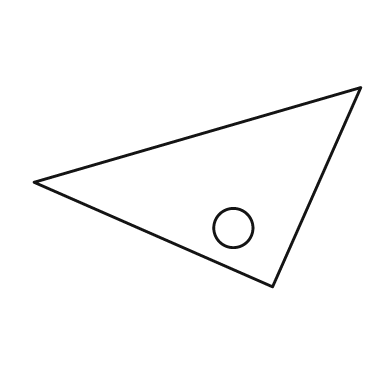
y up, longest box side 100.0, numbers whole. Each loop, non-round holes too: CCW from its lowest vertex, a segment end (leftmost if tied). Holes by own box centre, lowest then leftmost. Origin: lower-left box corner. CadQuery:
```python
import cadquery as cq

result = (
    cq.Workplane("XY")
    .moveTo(73.0, 0.0)
    .lineTo(100.0, 61.0)
    .lineTo(0.0, 32.0)
    .close()
    .moveTo(61.0, 18.0)
    .circle(6.0)
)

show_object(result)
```